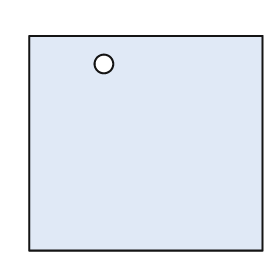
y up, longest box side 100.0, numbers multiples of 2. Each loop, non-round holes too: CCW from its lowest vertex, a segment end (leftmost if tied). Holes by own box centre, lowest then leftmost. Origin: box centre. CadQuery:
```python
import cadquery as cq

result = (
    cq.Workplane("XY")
    .moveTo(-50.0, -46.0)
    .lineTo(50.0, -46.0)
    .lineTo(50.0, 46.0)
    .lineTo(-50.0, 46.0)
    .close()
    .moveTo(-18.0, 34.0)
    .circle(4.0)
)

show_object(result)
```